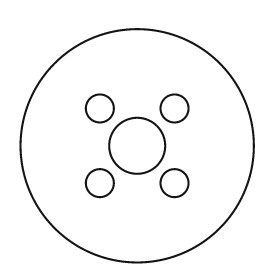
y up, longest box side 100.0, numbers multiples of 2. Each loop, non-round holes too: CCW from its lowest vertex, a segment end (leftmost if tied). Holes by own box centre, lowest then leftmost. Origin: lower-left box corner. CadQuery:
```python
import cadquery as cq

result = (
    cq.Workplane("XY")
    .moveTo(50.0, 50.0)
    .circle(50.0)
    .moveTo(34.0, 34.0)
    .circle(6.0)
    .moveTo(66.0, 34.0)
    .circle(6.0)
    .moveTo(50.0, 50.0)
    .circle(12.0)
    .moveTo(34.0, 66.0)
    .circle(6.0)
    .moveTo(66.0, 66.0)
    .circle(6.0)
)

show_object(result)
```